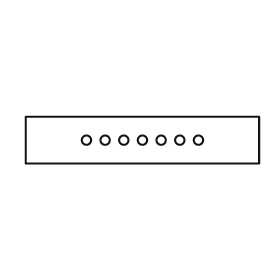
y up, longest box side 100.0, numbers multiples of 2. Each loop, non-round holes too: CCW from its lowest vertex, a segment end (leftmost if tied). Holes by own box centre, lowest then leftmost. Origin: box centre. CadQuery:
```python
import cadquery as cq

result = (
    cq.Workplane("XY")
    .moveTo(-50.0, -10.0)
    .lineTo(50.0, -10.0)
    .lineTo(50.0, 10.0)
    .lineTo(-50.0, 10.0)
    .close()
    .moveTo(-24.0, 0.0)
    .circle(2.0)
    .moveTo(-16.0, 0.0)
    .circle(2.0)
    .moveTo(-8.0, 0.0)
    .circle(2.0)
    .moveTo(0.0, 0.0)
    .circle(2.0)
    .moveTo(8.0, 0.0)
    .circle(2.0)
    .moveTo(16.0, 0.0)
    .circle(2.0)
    .moveTo(24.0, 0.0)
    .circle(2.0)
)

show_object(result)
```